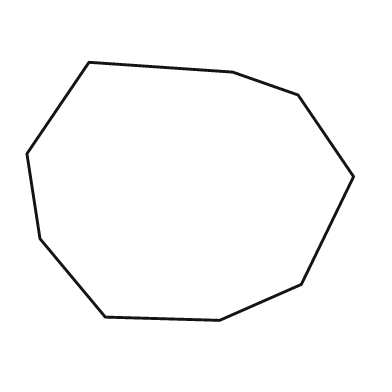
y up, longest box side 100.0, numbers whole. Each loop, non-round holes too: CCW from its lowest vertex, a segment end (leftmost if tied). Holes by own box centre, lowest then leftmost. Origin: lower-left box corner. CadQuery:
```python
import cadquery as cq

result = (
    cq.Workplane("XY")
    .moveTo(59.0, 0.0)
    .lineTo(84.0, 11.0)
    .lineTo(100.0, 44.0)
    .lineTo(83.0, 69.0)
    .lineTo(63.0, 76.0)
    .lineTo(19.0, 79.0)
    .lineTo(0.0, 51.0)
    .lineTo(4.0, 25.0)
    .lineTo(24.0, 1.0)
    .close()
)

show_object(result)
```